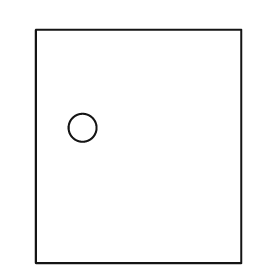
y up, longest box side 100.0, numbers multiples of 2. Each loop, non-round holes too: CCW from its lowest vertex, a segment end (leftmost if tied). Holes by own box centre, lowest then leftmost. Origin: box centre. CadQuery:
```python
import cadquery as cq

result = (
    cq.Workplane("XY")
    .moveTo(-44.0, -50.0)
    .lineTo(44.0, -50.0)
    .lineTo(44.0, 50.0)
    .lineTo(-44.0, 50.0)
    .close()
    .moveTo(-24.0, 8.0)
    .circle(6.0)
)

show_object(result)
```